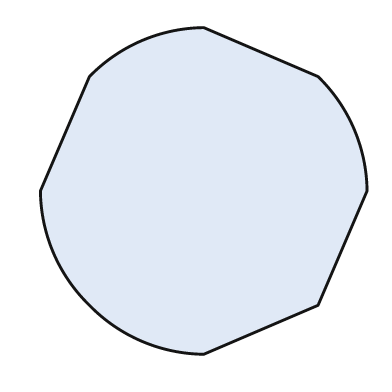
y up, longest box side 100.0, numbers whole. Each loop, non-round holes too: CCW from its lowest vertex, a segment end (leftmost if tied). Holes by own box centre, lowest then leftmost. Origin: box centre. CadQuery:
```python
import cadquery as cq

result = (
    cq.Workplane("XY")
    .moveTo(0.0, -50.0)
    .lineTo(35.0, -35.0)
    .lineTo(50.0, 0.0)
    .threePointArc((46.0, 19.0), (35.0, 35.0))
    .lineTo(0.0, 50.0)
    .threePointArc((-19.0, 46.0), (-35.0, 35.0))
    .lineTo(-50.0, 0.0)
    .threePointArc((-46.0, -19.0), (-35.0, -35.0))
    .threePointArc((-19.0, -46.0), (0.0, -50.0))
    .close()
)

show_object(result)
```